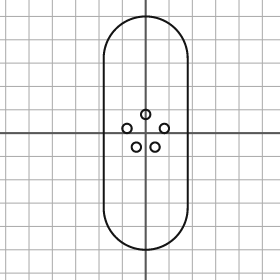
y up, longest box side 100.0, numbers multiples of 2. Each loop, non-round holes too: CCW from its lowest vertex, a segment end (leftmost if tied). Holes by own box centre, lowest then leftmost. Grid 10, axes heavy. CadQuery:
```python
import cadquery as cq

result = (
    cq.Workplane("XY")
    .moveTo(-18.0, -32.0)
    .threePointArc((0.0, -50.0), (18.0, -32.0))
    .lineTo(18.0, 32.0)
    .threePointArc((0.0, 50.0), (-18.0, 32.0))
    .close()
    .moveTo(-4.0, -6.0)
    .circle(2.0)
    .moveTo(4.0, -6.0)
    .circle(2.0)
    .moveTo(-8.0, 2.0)
    .circle(2.0)
    .moveTo(8.0, 2.0)
    .circle(2.0)
    .moveTo(0.0, 8.0)
    .circle(2.0)
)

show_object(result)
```